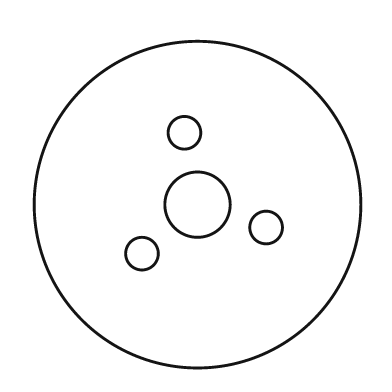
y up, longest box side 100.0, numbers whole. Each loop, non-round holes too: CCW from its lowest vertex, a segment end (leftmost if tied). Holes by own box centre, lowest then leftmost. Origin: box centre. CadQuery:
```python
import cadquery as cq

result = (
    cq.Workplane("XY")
    .moveTo(0.0, 0.0)
    .circle(50.0)
    .moveTo(-17.0, -15.0)
    .circle(5.0)
    .moveTo(21.0, -7.0)
    .circle(5.0)
    .moveTo(0.0, 0.0)
    .circle(10.0)
    .moveTo(-4.0, 22.0)
    .circle(5.0)
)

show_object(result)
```